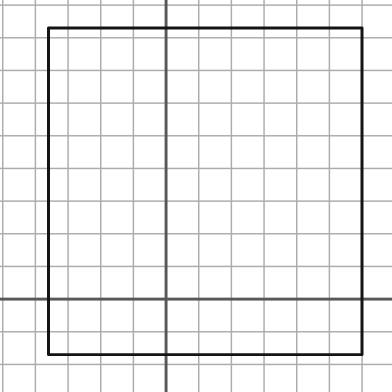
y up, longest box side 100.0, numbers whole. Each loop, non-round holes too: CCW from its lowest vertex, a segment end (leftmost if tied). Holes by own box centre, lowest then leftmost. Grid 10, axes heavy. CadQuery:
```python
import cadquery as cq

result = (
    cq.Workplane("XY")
    .moveTo(-36.0, -17.0)
    .lineTo(60.0, -17.0)
    .lineTo(60.0, 83.0)
    .lineTo(-36.0, 83.0)
    .close()
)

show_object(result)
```